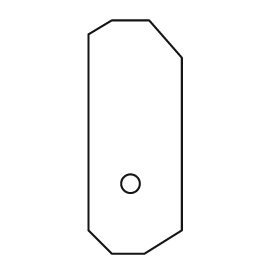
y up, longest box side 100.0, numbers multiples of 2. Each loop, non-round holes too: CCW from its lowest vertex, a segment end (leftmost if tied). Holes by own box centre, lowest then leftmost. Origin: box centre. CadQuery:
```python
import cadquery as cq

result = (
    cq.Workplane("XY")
    .moveTo(-10.0, -50.0)
    .lineTo(4.0, -50.0)
    .lineTo(20.0, -40.0)
    .lineTo(20.0, 34.0)
    .lineTo(6.0, 50.0)
    .lineTo(-10.0, 50.0)
    .lineTo(-20.0, 44.0)
    .lineTo(-20.0, -40.0)
    .close()
    .moveTo(-2.0, -20.0)
    .circle(4.0)
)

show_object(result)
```